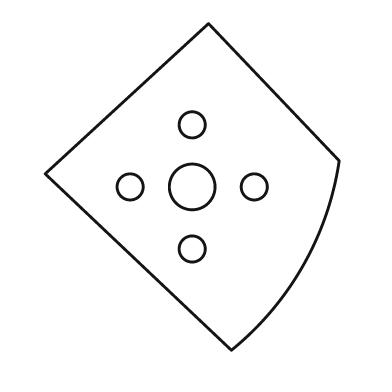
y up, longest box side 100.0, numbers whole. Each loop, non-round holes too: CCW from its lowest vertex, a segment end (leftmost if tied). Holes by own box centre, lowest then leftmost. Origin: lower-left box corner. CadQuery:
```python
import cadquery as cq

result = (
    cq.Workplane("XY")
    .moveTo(57.0, 0.0)
    .threePointArc((79.0, 26.0), (90.0, 58.0))
    .lineTo(50.0, 100.0)
    .lineTo(0.0, 54.0)
    .close()
    .moveTo(45.0, 31.0)
    .circle(4.0)
    .moveTo(26.0, 50.0)
    .circle(4.0)
    .moveTo(45.0, 50.0)
    .circle(7.0)
    .moveTo(64.0, 50.0)
    .circle(4.0)
    .moveTo(45.0, 69.0)
    .circle(4.0)
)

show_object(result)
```